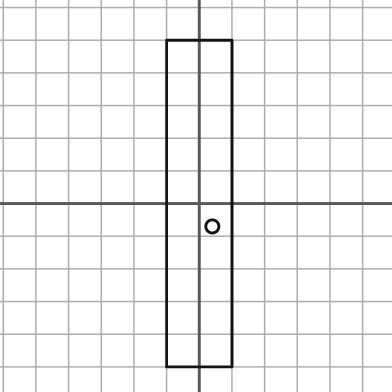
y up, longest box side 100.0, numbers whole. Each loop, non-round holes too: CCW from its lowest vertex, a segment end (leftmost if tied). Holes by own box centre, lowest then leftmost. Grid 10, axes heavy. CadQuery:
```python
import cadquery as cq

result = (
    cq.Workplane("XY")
    .moveTo(-10.0, -50.0)
    .lineTo(10.0, -50.0)
    .lineTo(10.0, 50.0)
    .lineTo(-10.0, 50.0)
    .close()
    .moveTo(4.0, -7.0)
    .circle(2.0)
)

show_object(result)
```